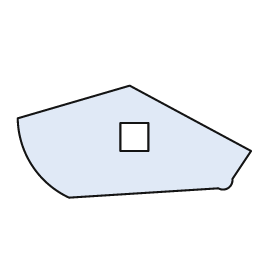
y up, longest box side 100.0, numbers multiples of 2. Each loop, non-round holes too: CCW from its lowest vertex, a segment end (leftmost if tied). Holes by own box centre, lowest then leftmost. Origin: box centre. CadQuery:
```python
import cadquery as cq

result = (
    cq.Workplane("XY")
    .moveTo(-28.0, -24.0)
    .lineTo(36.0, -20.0)
    .threePointArc((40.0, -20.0), (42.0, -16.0))
    .lineTo(50.0, -4.0)
    .lineTo(-2.0, 24.0)
    .lineTo(-50.0, 10.0)
    .threePointArc((-44.0, -10.0), (-28.0, -24.0))
    .close()
    .moveTo(-6.0, -4.0)
    .lineTo(6.0, -4.0)
    .lineTo(6.0, 8.0)
    .lineTo(-6.0, 8.0)
    .close()
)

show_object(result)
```